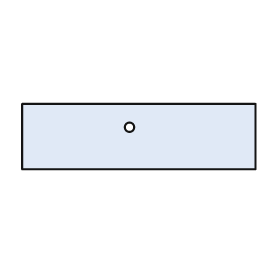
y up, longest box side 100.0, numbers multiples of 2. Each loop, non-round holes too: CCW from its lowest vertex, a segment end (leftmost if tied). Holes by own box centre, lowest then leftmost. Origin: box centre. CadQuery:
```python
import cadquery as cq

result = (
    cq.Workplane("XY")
    .moveTo(-50.0, -14.0)
    .lineTo(50.0, -14.0)
    .lineTo(50.0, 14.0)
    .lineTo(-50.0, 14.0)
    .close()
    .moveTo(-4.0, 4.0)
    .circle(2.0)
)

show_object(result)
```